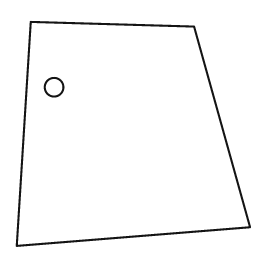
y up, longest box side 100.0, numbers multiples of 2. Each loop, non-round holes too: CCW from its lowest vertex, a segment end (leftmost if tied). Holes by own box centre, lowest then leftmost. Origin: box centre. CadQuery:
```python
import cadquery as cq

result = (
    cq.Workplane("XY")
    .moveTo(-50.0, -48.0)
    .lineTo(50.0, -40.0)
    .lineTo(26.0, 46.0)
    .lineTo(-44.0, 48.0)
    .close()
    .moveTo(-34.0, 20.0)
    .circle(4.0)
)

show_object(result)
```